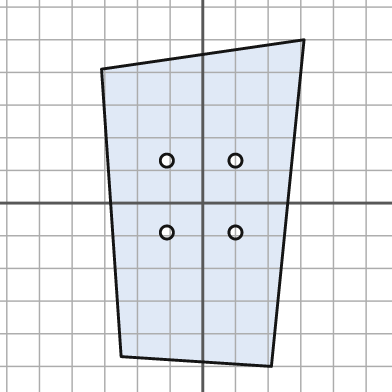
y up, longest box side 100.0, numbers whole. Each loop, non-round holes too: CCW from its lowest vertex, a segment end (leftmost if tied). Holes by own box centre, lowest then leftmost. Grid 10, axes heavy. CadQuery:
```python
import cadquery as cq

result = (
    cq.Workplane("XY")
    .moveTo(21.0, -50.0)
    .lineTo(31.0, 50.0)
    .lineTo(-31.0, 41.0)
    .lineTo(-25.0, -47.0)
    .close()
    .moveTo(-11.0, -9.0)
    .circle(2.0)
    .moveTo(10.0, -9.0)
    .circle(2.0)
    .moveTo(-11.0, 13.0)
    .circle(2.0)
    .moveTo(10.0, 13.0)
    .circle(2.0)
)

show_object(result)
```